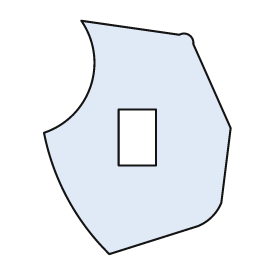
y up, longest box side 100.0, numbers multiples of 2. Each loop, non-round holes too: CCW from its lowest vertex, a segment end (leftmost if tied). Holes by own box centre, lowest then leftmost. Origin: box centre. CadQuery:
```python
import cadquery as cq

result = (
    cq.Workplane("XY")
    .moveTo(-12.0, -50.0)
    .lineTo(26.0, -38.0)
    .threePointArc((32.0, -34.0), (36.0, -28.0))
    .lineTo(40.0, 4.0)
    .lineTo(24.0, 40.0)
    .threePointArc((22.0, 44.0), (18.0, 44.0))
    .lineTo(-24.0, 50.0)
    .threePointArc((-20.0, 22.0), (-40.0, 2.0))
    .threePointArc((-30.0, -26.0), (-12.0, -50.0))
    .close()
    .moveTo(-8.0, -12.0)
    .lineTo(8.0, -12.0)
    .lineTo(8.0, 12.0)
    .lineTo(-8.0, 12.0)
    .close()
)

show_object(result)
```